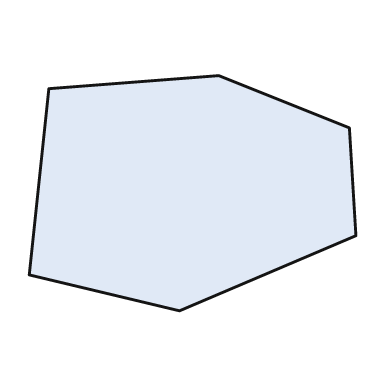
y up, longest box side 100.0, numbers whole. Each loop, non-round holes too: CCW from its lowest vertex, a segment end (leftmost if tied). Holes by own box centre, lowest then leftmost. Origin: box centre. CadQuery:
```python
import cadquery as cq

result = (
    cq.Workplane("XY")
    .moveTo(-4.0, -36.0)
    .lineTo(50.0, -13.0)
    .lineTo(48.0, 20.0)
    .lineTo(8.0, 36.0)
    .lineTo(-44.0, 32.0)
    .lineTo(-50.0, -25.0)
    .close()
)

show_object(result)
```